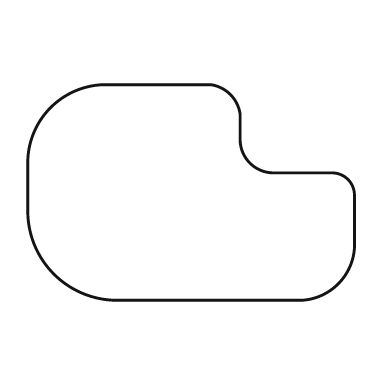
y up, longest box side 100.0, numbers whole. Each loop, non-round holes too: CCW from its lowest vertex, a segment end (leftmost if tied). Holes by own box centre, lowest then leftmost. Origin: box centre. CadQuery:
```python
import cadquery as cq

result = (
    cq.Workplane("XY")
    .moveTo(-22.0, -33.0)
    .lineTo(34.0, -33.0)
    .threePointArc((45.0, -28.0), (50.0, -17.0))
    .lineTo(50.0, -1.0)
    .threePointArc((48.0, 4.0), (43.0, 6.0))
    .lineTo(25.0, 6.0)
    .threePointArc((18.0, 9.0), (15.0, 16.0))
    .lineTo(15.0, 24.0)
    .threePointArc((12.0, 30.0), (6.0, 33.0))
    .lineTo(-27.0, 33.0)
    .threePointArc((-43.0, 26.0), (-50.0, 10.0))
    .lineTo(-50.0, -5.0)
    .threePointArc((-42.0, -25.0), (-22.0, -33.0))
    .close()
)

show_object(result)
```